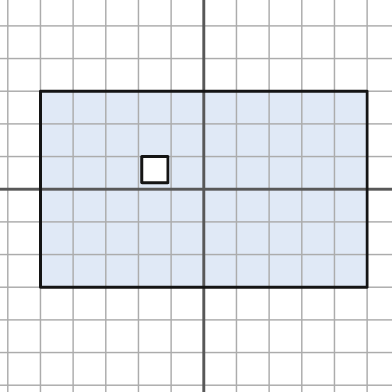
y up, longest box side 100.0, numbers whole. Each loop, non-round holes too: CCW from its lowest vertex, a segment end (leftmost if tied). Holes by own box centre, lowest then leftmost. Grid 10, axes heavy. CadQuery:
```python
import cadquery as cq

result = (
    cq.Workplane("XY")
    .moveTo(-50.0, -30.0)
    .lineTo(50.0, -30.0)
    .lineTo(50.0, 30.0)
    .lineTo(-50.0, 30.0)
    .close()
    .moveTo(-19.0, 2.0)
    .lineTo(-11.0, 2.0)
    .lineTo(-11.0, 10.0)
    .lineTo(-19.0, 10.0)
    .close()
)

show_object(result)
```